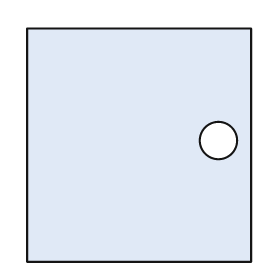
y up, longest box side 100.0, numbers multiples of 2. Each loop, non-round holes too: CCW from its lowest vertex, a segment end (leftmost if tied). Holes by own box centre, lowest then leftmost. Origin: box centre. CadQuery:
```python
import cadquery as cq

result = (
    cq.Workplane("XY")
    .moveTo(-48.0, -50.0)
    .lineTo(48.0, -50.0)
    .lineTo(48.0, 50.0)
    .lineTo(-48.0, 50.0)
    .close()
    .moveTo(34.0, 2.0)
    .circle(8.0)
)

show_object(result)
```